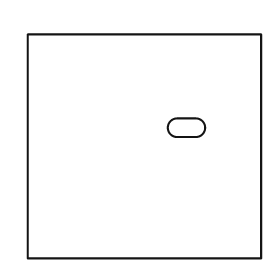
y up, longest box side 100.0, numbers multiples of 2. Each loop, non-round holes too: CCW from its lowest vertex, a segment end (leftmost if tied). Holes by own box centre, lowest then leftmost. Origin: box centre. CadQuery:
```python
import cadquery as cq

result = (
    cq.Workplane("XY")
    .moveTo(-50.0, -48.0)
    .lineTo(50.0, -48.0)
    .lineTo(50.0, 48.0)
    .lineTo(-50.0, 48.0)
    .close()
    .moveTo(14.0, 4.0)
    .lineTo(22.0, 4.0)
    .threePointArc((26.0, 8.0), (22.0, 12.0))
    .lineTo(14.0, 12.0)
    .threePointArc((10.0, 8.0), (14.0, 4.0))
    .close()
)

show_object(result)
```